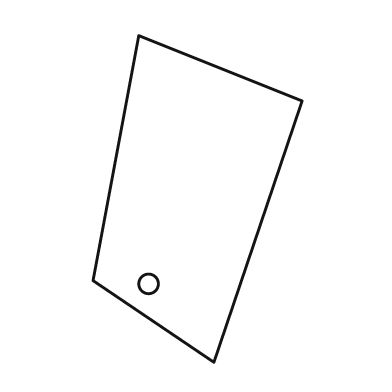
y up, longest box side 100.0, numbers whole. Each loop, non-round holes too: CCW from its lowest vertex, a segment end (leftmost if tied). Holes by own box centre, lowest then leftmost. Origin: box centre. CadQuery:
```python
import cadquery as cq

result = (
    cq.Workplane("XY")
    .moveTo(5.0, -50.0)
    .lineTo(32.0, 30.0)
    .lineTo(-18.0, 50.0)
    .lineTo(-32.0, -25.0)
    .close()
    .moveTo(-15.0, -26.0)
    .circle(3.0)
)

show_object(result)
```